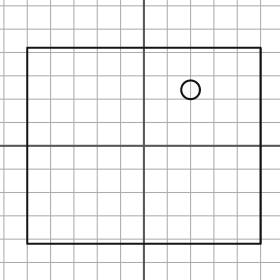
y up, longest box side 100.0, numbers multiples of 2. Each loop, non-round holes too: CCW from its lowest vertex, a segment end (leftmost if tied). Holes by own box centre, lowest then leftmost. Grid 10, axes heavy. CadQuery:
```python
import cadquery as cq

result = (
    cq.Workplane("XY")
    .moveTo(-50.0, -42.0)
    .lineTo(50.0, -42.0)
    .lineTo(50.0, 42.0)
    .lineTo(-50.0, 42.0)
    .close()
    .moveTo(20.0, 24.0)
    .circle(4.0)
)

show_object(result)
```